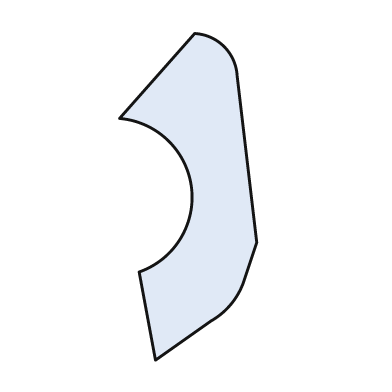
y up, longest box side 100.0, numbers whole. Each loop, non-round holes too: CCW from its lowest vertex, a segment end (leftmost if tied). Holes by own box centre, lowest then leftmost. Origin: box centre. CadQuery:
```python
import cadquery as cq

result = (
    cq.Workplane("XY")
    .moveTo(-10.0, -50.0)
    .lineTo(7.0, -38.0)
    .threePointArc((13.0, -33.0), (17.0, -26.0))
    .lineTo(21.0, -14.0)
    .lineTo(15.0, 37.0)
    .threePointArc((11.0, 46.0), (2.0, 50.0))
    .lineTo(-21.0, 24.0)
    .threePointArc((1.0, 3.0), (-15.0, -23.0))
    .close()
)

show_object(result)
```